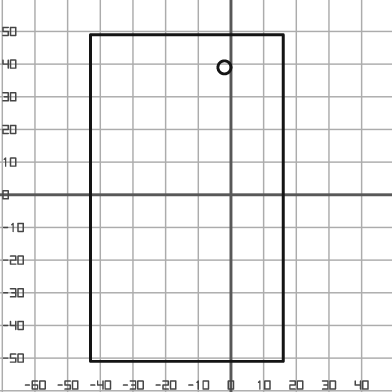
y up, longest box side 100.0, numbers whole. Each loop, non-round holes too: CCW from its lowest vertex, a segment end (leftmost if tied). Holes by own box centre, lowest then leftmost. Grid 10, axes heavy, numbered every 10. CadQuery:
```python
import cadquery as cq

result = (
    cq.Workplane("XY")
    .moveTo(-43.0, -51.0)
    .lineTo(16.0, -51.0)
    .lineTo(16.0, 49.0)
    .lineTo(-43.0, 49.0)
    .close()
    .moveTo(-2.0, 39.0)
    .circle(2.0)
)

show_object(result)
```